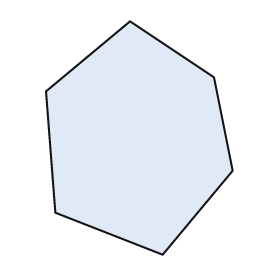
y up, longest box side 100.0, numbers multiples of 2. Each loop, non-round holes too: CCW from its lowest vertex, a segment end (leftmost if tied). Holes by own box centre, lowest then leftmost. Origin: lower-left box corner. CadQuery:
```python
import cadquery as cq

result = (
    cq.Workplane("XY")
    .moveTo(50.0, 0.0)
    .lineTo(80.0, 36.0)
    .lineTo(72.0, 76.0)
    .lineTo(36.0, 100.0)
    .lineTo(0.0, 70.0)
    .lineTo(4.0, 18.0)
    .close()
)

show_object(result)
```